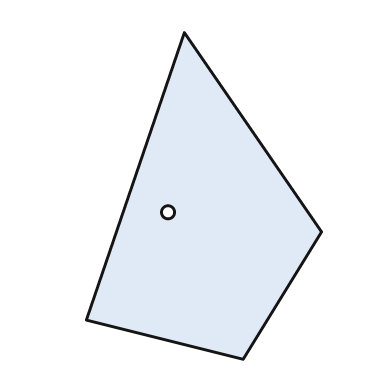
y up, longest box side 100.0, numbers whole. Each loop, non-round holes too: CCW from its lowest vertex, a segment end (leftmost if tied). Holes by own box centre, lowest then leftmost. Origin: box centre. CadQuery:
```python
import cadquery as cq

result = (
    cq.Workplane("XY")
    .moveTo(12.0, -50.0)
    .lineTo(36.0, -11.0)
    .lineTo(-6.0, 50.0)
    .lineTo(-36.0, -38.0)
    .close()
    .moveTo(-11.0, -5.0)
    .circle(2.0)
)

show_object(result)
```